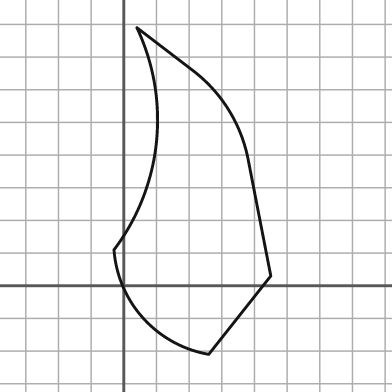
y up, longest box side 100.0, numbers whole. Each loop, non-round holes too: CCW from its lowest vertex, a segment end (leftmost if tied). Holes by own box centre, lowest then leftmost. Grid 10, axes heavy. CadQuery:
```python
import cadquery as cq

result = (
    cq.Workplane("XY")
    .moveTo(26.0, -21.0)
    .lineTo(45.0, 3.0)
    .lineTo(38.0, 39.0)
    .threePointArc((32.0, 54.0), (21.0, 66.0))
    .lineTo(4.0, 79.0)
    .threePointArc((10.0, 44.0), (-3.0, 11.0))
    .threePointArc((6.0, -10.0), (26.0, -21.0))
    .close()
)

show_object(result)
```